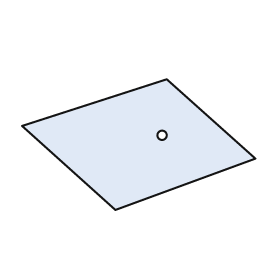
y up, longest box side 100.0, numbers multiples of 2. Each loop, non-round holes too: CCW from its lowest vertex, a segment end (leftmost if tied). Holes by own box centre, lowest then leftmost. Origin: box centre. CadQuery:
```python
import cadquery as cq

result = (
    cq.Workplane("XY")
    .moveTo(-10.0, -28.0)
    .lineTo(50.0, -6.0)
    .lineTo(12.0, 28.0)
    .lineTo(-50.0, 8.0)
    .close()
    .moveTo(10.0, 4.0)
    .circle(2.0)
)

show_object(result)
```